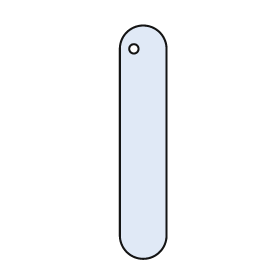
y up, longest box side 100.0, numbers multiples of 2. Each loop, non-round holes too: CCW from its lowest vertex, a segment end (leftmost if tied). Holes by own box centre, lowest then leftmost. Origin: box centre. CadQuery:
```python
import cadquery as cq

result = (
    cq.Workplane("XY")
    .moveTo(-10.0, -40.0)
    .threePointArc((0.0, -50.0), (10.0, -40.0))
    .lineTo(10.0, 40.0)
    .threePointArc((0.0, 50.0), (-10.0, 40.0))
    .close()
    .moveTo(-4.0, 40.0)
    .circle(2.0)
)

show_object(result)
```